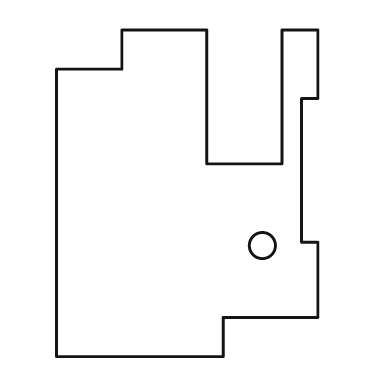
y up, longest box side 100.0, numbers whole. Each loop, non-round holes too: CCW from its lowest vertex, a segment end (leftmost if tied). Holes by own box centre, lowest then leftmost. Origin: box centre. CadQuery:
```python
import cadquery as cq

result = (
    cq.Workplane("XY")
    .moveTo(-40.0, -50.0)
    .lineTo(11.0, -50.0)
    .lineTo(11.0, -38.0)
    .lineTo(40.0, -38.0)
    .lineTo(40.0, -15.0)
    .lineTo(35.0, -15.0)
    .lineTo(35.0, 29.0)
    .lineTo(40.0, 29.0)
    .lineTo(40.0, 50.0)
    .lineTo(29.0, 50.0)
    .lineTo(29.0, 9.0)
    .lineTo(6.0, 9.0)
    .lineTo(6.0, 50.0)
    .lineTo(-20.0, 50.0)
    .lineTo(-20.0, 38.0)
    .lineTo(-40.0, 38.0)
    .close()
    .moveTo(23.0, -16.0)
    .circle(4.0)
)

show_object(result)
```